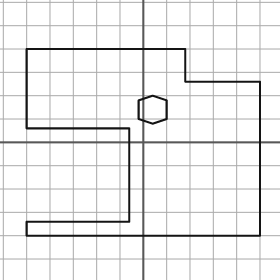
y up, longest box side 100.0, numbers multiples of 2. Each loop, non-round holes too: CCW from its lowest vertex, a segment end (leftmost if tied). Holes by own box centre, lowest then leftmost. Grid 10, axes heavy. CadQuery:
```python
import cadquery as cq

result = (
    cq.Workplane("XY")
    .moveTo(-50.0, -40.0)
    .lineTo(50.0, -40.0)
    .lineTo(50.0, 26.0)
    .lineTo(18.0, 26.0)
    .lineTo(18.0, 40.0)
    .lineTo(-50.0, 40.0)
    .lineTo(-50.0, 6.0)
    .lineTo(-6.0, 6.0)
    .lineTo(-6.0, -34.0)
    .lineTo(-50.0, -34.0)
    .close()
    .moveTo(4.0, 8.0)
    .lineTo(10.0, 10.0)
    .lineTo(10.0, 18.0)
    .lineTo(4.0, 20.0)
    .lineTo(-2.0, 18.0)
    .lineTo(-2.0, 10.0)
    .close()
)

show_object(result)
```